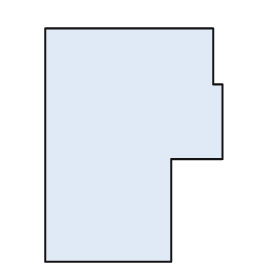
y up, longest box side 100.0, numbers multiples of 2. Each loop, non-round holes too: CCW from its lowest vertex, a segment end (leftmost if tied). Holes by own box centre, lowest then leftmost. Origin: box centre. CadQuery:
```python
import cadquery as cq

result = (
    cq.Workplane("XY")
    .moveTo(-38.0, -50.0)
    .lineTo(16.0, -50.0)
    .lineTo(16.0, -6.0)
    .lineTo(38.0, -6.0)
    .lineTo(38.0, 26.0)
    .lineTo(34.0, 26.0)
    .lineTo(34.0, 50.0)
    .lineTo(-38.0, 50.0)
    .close()
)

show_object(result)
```